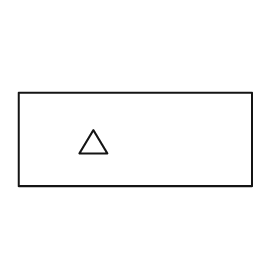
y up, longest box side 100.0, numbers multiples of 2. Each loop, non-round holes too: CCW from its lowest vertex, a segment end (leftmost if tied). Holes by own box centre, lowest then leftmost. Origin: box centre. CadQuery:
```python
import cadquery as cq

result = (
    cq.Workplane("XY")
    .moveTo(-50.0, -20.0)
    .lineTo(50.0, -20.0)
    .lineTo(50.0, 20.0)
    .lineTo(-50.0, 20.0)
    .close()
    .moveTo(-24.0, -6.0)
    .lineTo(-12.0, -6.0)
    .lineTo(-18.0, 4.0)
    .close()
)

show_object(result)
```